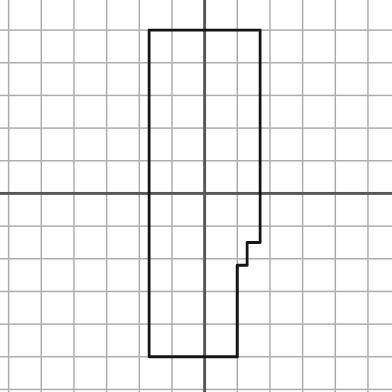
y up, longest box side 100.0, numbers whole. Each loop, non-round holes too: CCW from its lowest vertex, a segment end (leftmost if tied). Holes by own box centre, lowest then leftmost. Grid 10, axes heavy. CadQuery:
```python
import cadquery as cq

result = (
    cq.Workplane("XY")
    .moveTo(-17.0, -50.0)
    .lineTo(10.0, -50.0)
    .lineTo(10.0, -22.0)
    .lineTo(13.0, -22.0)
    .lineTo(13.0, -15.0)
    .lineTo(17.0, -15.0)
    .lineTo(17.0, 50.0)
    .lineTo(-17.0, 50.0)
    .close()
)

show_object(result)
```